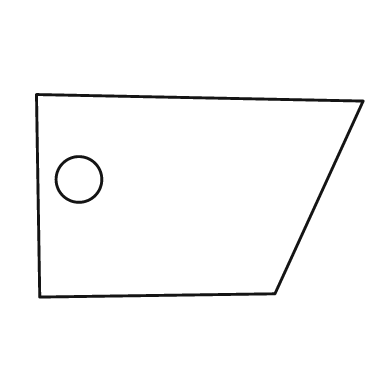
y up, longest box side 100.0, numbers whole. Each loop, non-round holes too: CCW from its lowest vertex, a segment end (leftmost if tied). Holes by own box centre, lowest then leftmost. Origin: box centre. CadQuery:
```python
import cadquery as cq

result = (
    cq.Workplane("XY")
    .moveTo(-49.0, -31.0)
    .lineTo(23.0, -30.0)
    .lineTo(50.0, 29.0)
    .lineTo(-50.0, 31.0)
    .close()
    .moveTo(-37.0, 5.0)
    .circle(7.0)
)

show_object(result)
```